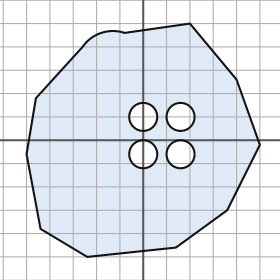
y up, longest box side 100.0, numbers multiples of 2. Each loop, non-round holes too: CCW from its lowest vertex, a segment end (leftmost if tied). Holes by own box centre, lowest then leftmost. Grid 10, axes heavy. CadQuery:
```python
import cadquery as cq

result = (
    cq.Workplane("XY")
    .moveTo(-24.0, -50.0)
    .lineTo(14.0, -46.0)
    .lineTo(36.0, -30.0)
    .lineTo(50.0, -2.0)
    .lineTo(40.0, 26.0)
    .lineTo(20.0, 50.0)
    .lineTo(-8.0, 46.0)
    .threePointArc((-18.0, 46.0), (-26.0, 40.0))
    .lineTo(-46.0, 18.0)
    .lineTo(-50.0, -6.0)
    .lineTo(-44.0, -38.0)
    .close()
    .moveTo(0.0, -6.0)
    .circle(6.0)
    .moveTo(16.0, -6.0)
    .circle(6.0)
    .moveTo(0.0, 10.0)
    .circle(6.0)
    .moveTo(16.0, 10.0)
    .circle(6.0)
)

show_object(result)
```